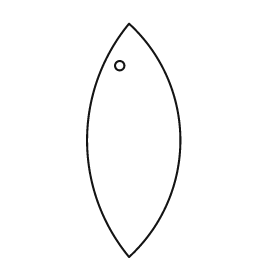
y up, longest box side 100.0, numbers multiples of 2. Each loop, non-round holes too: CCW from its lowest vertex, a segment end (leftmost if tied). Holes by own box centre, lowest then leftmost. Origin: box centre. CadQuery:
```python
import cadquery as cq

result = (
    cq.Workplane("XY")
    .moveTo(-2.0, -50.0)
    .threePointArc((20.0, 0.0), (-2.0, 50.0))
    .threePointArc((-20.0, 0.0), (-2.0, -50.0))
    .close()
    .moveTo(-6.0, 32.0)
    .circle(2.0)
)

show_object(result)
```